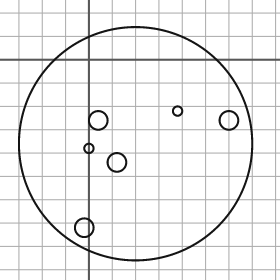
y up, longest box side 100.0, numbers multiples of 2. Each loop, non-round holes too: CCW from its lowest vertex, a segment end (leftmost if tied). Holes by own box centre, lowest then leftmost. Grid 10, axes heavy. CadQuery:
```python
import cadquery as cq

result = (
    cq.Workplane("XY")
    .moveTo(20.0, -36.0)
    .circle(50.0)
    .moveTo(-2.0, -72.0)
    .circle(4.0)
    .moveTo(12.0, -44.0)
    .circle(4.0)
    .moveTo(0.0, -38.0)
    .circle(2.0)
    .moveTo(4.0, -26.0)
    .circle(4.0)
    .moveTo(60.0, -26.0)
    .circle(4.0)
    .moveTo(38.0, -22.0)
    .circle(2.0)
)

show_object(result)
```